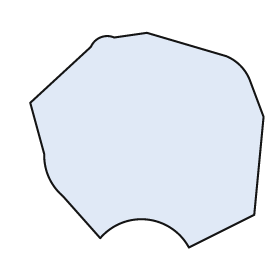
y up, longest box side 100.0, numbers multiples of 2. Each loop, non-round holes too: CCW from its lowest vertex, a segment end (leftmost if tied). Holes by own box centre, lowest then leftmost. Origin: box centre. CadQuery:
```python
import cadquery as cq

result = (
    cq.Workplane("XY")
    .moveTo(18.0, -46.0)
    .lineTo(46.0, -32.0)
    .lineTo(50.0, 10.0)
    .lineTo(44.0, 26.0)
    .threePointArc((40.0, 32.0), (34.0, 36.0))
    .lineTo(0.0, 46.0)
    .lineTo(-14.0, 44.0)
    .threePointArc((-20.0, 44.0), (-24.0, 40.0))
    .lineTo(-50.0, 16.0)
    .lineTo(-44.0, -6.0)
    .threePointArc((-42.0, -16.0), (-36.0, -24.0))
    .lineTo(-20.0, -42.0)
    .threePointArc((0.0, -34.0), (18.0, -46.0))
    .close()
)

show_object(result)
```